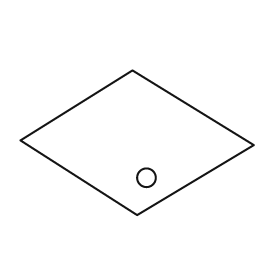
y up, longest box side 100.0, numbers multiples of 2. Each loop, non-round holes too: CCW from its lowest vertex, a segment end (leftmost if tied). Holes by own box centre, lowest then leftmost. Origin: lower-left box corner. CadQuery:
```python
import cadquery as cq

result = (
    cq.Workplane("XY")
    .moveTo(50.0, 0.0)
    .lineTo(100.0, 30.0)
    .lineTo(48.0, 62.0)
    .lineTo(0.0, 32.0)
    .close()
    .moveTo(54.0, 16.0)
    .circle(4.0)
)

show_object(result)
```